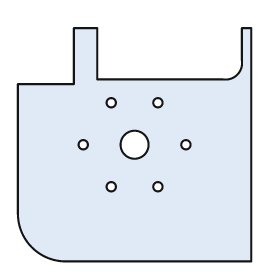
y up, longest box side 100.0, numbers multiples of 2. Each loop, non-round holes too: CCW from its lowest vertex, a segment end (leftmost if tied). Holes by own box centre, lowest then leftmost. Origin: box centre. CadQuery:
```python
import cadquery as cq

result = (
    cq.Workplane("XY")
    .moveTo(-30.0, -50.0)
    .lineTo(50.0, -50.0)
    .lineTo(50.0, 50.0)
    .lineTo(46.0, 50.0)
    .lineTo(46.0, 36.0)
    .threePointArc((44.0, 30.0), (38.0, 28.0))
    .lineTo(-16.0, 28.0)
    .lineTo(-16.0, 50.0)
    .lineTo(-26.0, 50.0)
    .lineTo(-26.0, 26.0)
    .lineTo(-50.0, 26.0)
    .lineTo(-50.0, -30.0)
    .threePointArc((-44.0, -44.0), (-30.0, -50.0))
    .close()
    .moveTo(-10.0, -18.0)
    .circle(2.0)
    .moveTo(10.0, -18.0)
    .circle(2.0)
    .moveTo(-22.0, 0.0)
    .circle(2.0)
    .moveTo(0.0, 0.0)
    .circle(6.0)
    .moveTo(22.0, 0.0)
    .circle(2.0)
    .moveTo(-10.0, 18.0)
    .circle(2.0)
    .moveTo(10.0, 18.0)
    .circle(2.0)
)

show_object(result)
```